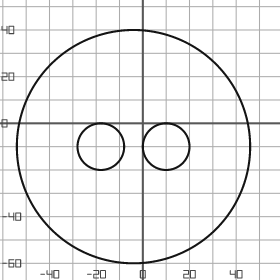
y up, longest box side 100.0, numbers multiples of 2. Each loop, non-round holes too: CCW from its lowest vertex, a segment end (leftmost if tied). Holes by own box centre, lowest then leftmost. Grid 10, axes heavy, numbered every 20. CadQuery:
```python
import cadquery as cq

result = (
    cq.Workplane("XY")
    .moveTo(-4.0, -10.0)
    .circle(50.0)
    .moveTo(-18.0, -10.0)
    .circle(10.0)
    .moveTo(10.0, -10.0)
    .circle(10.0)
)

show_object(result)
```